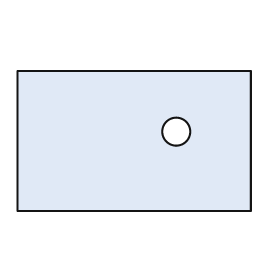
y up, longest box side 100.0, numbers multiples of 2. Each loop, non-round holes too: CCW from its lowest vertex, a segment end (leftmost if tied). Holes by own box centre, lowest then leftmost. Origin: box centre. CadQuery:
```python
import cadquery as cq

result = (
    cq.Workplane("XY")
    .moveTo(-50.0, -30.0)
    .lineTo(50.0, -30.0)
    .lineTo(50.0, 30.0)
    .lineTo(-50.0, 30.0)
    .close()
    .moveTo(18.0, 4.0)
    .circle(6.0)
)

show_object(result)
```